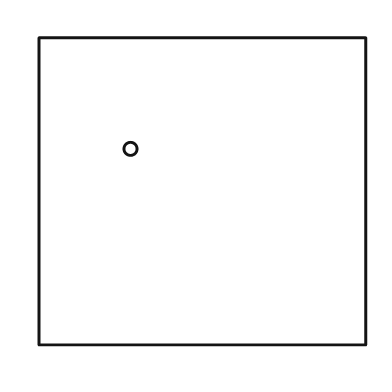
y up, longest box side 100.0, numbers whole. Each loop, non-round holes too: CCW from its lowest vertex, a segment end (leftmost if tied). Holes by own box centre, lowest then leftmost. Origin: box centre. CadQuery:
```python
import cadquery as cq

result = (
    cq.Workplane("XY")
    .moveTo(-50.0, -47.0)
    .lineTo(50.0, -47.0)
    .lineTo(50.0, 47.0)
    .lineTo(-50.0, 47.0)
    .close()
    .moveTo(-22.0, 13.0)
    .circle(2.0)
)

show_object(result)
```